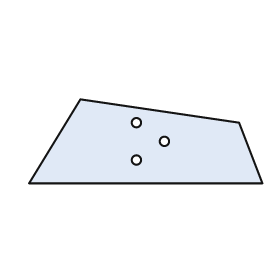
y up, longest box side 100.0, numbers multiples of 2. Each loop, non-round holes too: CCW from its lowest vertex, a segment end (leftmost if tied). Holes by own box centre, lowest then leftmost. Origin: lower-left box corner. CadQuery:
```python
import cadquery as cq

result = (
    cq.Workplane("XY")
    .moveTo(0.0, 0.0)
    .lineTo(100.0, 0.0)
    .lineTo(90.0, 26.0)
    .lineTo(22.0, 36.0)
    .close()
    .moveTo(46.0, 10.0)
    .circle(2.0)
    .moveTo(58.0, 18.0)
    .circle(2.0)
    .moveTo(46.0, 26.0)
    .circle(2.0)
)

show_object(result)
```